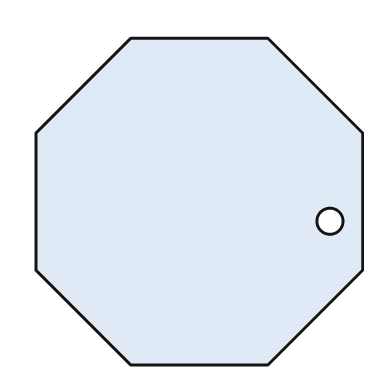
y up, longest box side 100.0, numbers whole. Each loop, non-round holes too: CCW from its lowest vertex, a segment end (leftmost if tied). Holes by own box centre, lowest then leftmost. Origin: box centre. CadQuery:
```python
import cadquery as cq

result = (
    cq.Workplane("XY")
    .moveTo(-21.0, -50.0)
    .lineTo(21.0, -50.0)
    .lineTo(50.0, -21.0)
    .lineTo(50.0, 21.0)
    .lineTo(21.0, 50.0)
    .lineTo(-21.0, 50.0)
    .lineTo(-50.0, 21.0)
    .lineTo(-50.0, -21.0)
    .close()
    .moveTo(40.0, -6.0)
    .circle(4.0)
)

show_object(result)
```